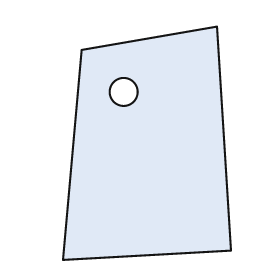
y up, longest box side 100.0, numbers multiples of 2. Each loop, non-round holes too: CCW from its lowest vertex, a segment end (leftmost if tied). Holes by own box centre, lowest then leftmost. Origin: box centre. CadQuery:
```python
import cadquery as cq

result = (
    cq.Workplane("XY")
    .moveTo(-36.0, -50.0)
    .lineTo(36.0, -46.0)
    .lineTo(30.0, 50.0)
    .lineTo(-28.0, 40.0)
    .close()
    .moveTo(-10.0, 22.0)
    .circle(6.0)
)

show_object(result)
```